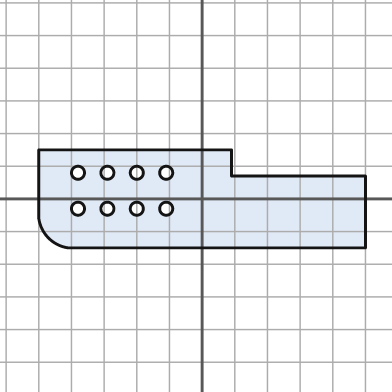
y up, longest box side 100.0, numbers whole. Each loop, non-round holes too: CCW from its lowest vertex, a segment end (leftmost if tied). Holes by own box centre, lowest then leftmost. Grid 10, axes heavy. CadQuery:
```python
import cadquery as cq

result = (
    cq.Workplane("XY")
    .moveTo(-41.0, -15.0)
    .lineTo(50.0, -15.0)
    .lineTo(50.0, 7.0)
    .lineTo(9.0, 7.0)
    .lineTo(9.0, 15.0)
    .lineTo(-50.0, 15.0)
    .lineTo(-50.0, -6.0)
    .threePointArc((-47.0, -12.0), (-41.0, -15.0))
    .close()
    .moveTo(-38.0, -3.0)
    .circle(2.0)
    .moveTo(-29.0, -3.0)
    .circle(2.0)
    .moveTo(-20.0, -3.0)
    .circle(2.0)
    .moveTo(-11.0, -3.0)
    .circle(2.0)
    .moveTo(-38.0, 8.0)
    .circle(2.0)
    .moveTo(-29.0, 8.0)
    .circle(2.0)
    .moveTo(-20.0, 8.0)
    .circle(2.0)
    .moveTo(-11.0, 8.0)
    .circle(2.0)
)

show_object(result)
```